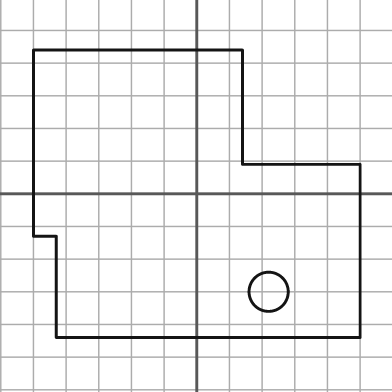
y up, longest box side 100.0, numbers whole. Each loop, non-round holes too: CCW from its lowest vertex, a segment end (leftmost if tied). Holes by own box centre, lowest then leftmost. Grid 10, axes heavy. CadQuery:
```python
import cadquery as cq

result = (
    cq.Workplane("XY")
    .moveTo(-43.0, -44.0)
    .lineTo(50.0, -44.0)
    .lineTo(50.0, 9.0)
    .lineTo(14.0, 9.0)
    .lineTo(14.0, 44.0)
    .lineTo(-50.0, 44.0)
    .lineTo(-50.0, -13.0)
    .lineTo(-43.0, -13.0)
    .close()
    .moveTo(22.0, -30.0)
    .circle(6.0)
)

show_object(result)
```